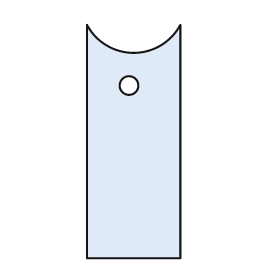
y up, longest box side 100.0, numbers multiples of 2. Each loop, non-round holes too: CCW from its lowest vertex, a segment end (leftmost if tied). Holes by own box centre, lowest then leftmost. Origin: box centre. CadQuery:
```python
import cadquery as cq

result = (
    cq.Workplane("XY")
    .moveTo(-20.0, -50.0)
    .lineTo(20.0, -50.0)
    .lineTo(20.0, 50.0)
    .threePointArc((0.0, 38.0), (-20.0, 50.0))
    .close()
    .moveTo(-2.0, 24.0)
    .circle(4.0)
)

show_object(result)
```